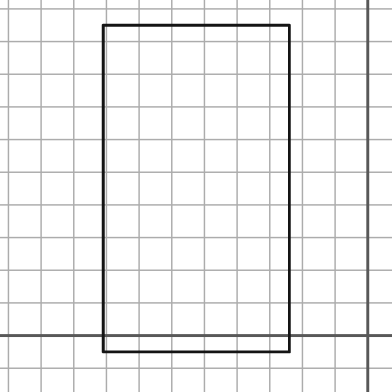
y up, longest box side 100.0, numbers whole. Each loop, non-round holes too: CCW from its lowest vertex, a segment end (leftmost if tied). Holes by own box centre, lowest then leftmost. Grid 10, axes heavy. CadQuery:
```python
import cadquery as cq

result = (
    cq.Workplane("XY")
    .moveTo(-81.0, -5.0)
    .lineTo(-24.0, -5.0)
    .lineTo(-24.0, 95.0)
    .lineTo(-81.0, 95.0)
    .close()
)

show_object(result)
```